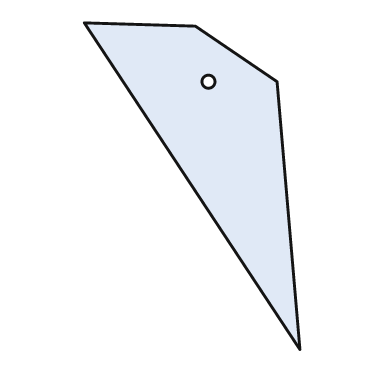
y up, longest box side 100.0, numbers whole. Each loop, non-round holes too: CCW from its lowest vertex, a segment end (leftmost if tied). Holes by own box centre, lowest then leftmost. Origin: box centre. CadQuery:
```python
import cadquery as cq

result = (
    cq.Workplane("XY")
    .moveTo(33.0, -50.0)
    .lineTo(26.0, 32.0)
    .lineTo(1.0, 49.0)
    .lineTo(-33.0, 50.0)
    .close()
    .moveTo(5.0, 32.0)
    .circle(2.0)
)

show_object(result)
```